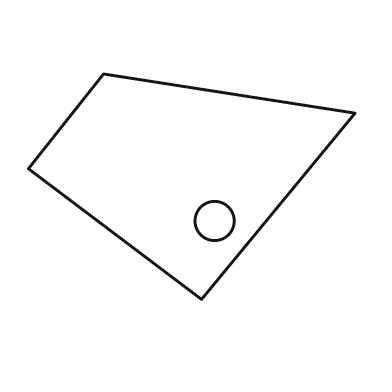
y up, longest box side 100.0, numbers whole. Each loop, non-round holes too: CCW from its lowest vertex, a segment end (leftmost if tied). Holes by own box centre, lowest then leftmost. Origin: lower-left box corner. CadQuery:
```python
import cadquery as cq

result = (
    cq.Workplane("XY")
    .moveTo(53.0, 0.0)
    .lineTo(100.0, 57.0)
    .lineTo(23.0, 69.0)
    .lineTo(0.0, 40.0)
    .close()
    .moveTo(57.0, 24.0)
    .circle(6.0)
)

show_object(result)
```